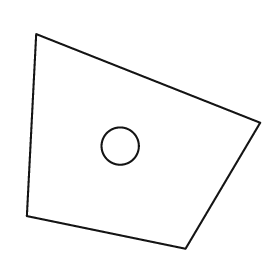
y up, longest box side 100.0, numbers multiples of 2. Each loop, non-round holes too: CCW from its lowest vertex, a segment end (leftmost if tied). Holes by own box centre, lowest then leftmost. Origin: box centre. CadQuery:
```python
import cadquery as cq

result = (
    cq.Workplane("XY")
    .moveTo(18.0, -46.0)
    .lineTo(50.0, 8.0)
    .lineTo(-46.0, 46.0)
    .lineTo(-50.0, -32.0)
    .close()
    .moveTo(-10.0, -2.0)
    .circle(8.0)
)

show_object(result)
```